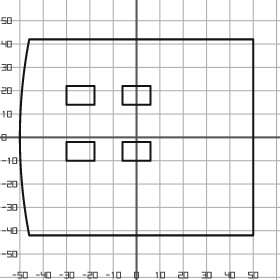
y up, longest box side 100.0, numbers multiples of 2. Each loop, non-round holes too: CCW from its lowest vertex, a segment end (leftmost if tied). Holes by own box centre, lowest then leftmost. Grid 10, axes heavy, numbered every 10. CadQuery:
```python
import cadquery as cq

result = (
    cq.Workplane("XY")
    .moveTo(-46.0, -42.0)
    .lineTo(50.0, -42.0)
    .lineTo(50.0, 42.0)
    .lineTo(-46.0, 42.0)
    .threePointArc((-50.0, 0.0), (-46.0, -42.0))
    .close()
    .moveTo(-30.0, -10.0)
    .lineTo(-18.0, -10.0)
    .lineTo(-18.0, -2.0)
    .lineTo(-30.0, -2.0)
    .close()
    .moveTo(-6.0, -10.0)
    .lineTo(6.0, -10.0)
    .lineTo(6.0, -2.0)
    .lineTo(-6.0, -2.0)
    .close()
    .moveTo(-30.0, 14.0)
    .lineTo(-18.0, 14.0)
    .lineTo(-18.0, 22.0)
    .lineTo(-30.0, 22.0)
    .close()
    .moveTo(-6.0, 14.0)
    .lineTo(6.0, 14.0)
    .lineTo(6.0, 22.0)
    .lineTo(-6.0, 22.0)
    .close()
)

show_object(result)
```